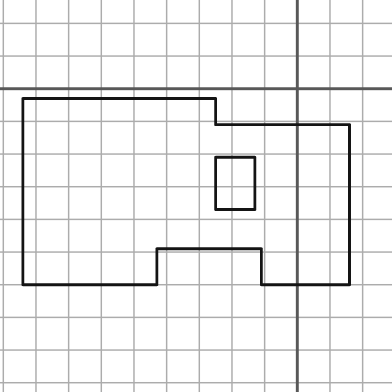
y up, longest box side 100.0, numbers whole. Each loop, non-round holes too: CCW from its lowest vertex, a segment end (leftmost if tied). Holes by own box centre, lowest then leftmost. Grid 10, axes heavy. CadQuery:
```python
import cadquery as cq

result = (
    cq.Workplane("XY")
    .moveTo(-84.0, -60.0)
    .lineTo(-43.0, -60.0)
    .lineTo(-43.0, -49.0)
    .lineTo(-11.0, -49.0)
    .lineTo(-11.0, -60.0)
    .lineTo(16.0, -60.0)
    .lineTo(16.0, -11.0)
    .lineTo(-25.0, -11.0)
    .lineTo(-25.0, -3.0)
    .lineTo(-84.0, -3.0)
    .close()
    .moveTo(-25.0, -37.0)
    .lineTo(-13.0, -37.0)
    .lineTo(-13.0, -21.0)
    .lineTo(-25.0, -21.0)
    .close()
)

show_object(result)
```